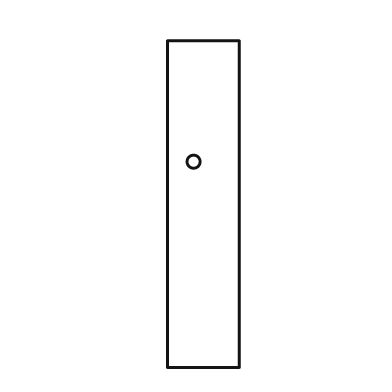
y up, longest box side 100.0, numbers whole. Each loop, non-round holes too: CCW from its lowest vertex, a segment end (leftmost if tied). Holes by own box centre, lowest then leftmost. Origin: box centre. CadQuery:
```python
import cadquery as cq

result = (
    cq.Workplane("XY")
    .moveTo(-11.0, -50.0)
    .lineTo(11.0, -50.0)
    .lineTo(11.0, 50.0)
    .lineTo(-11.0, 50.0)
    .close()
    .moveTo(-3.0, 13.0)
    .circle(2.0)
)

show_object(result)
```